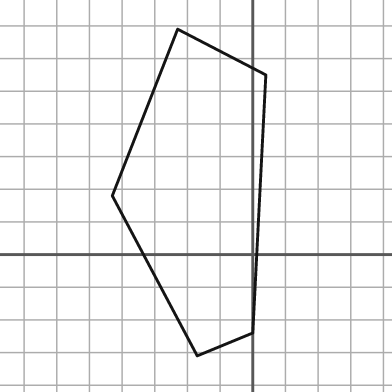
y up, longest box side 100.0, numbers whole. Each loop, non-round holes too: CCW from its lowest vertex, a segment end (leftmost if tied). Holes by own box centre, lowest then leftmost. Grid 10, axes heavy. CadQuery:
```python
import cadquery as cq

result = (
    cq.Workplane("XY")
    .moveTo(-17.0, -31.0)
    .lineTo(0.0, -24.0)
    .lineTo(4.0, 55.0)
    .lineTo(-23.0, 69.0)
    .lineTo(-43.0, 18.0)
    .close()
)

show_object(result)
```